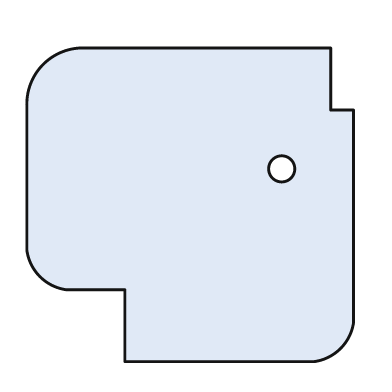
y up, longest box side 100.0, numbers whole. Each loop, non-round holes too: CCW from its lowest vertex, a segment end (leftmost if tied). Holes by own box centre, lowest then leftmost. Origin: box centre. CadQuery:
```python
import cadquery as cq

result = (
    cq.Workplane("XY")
    .moveTo(-20.0, -48.0)
    .lineTo(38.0, -48.0)
    .threePointArc((46.0, -44.0), (50.0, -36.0))
    .lineTo(50.0, 29.0)
    .lineTo(43.0, 29.0)
    .lineTo(43.0, 48.0)
    .lineTo(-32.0, 48.0)
    .threePointArc((-45.0, 43.0), (-50.0, 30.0))
    .lineTo(-50.0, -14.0)
    .threePointArc((-46.0, -22.0), (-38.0, -26.0))
    .lineTo(-20.0, -26.0)
    .close()
    .moveTo(28.0, 11.0)
    .circle(4.0)
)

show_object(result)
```